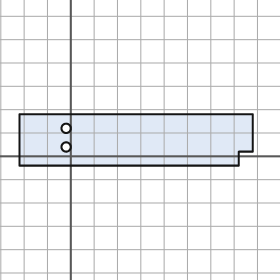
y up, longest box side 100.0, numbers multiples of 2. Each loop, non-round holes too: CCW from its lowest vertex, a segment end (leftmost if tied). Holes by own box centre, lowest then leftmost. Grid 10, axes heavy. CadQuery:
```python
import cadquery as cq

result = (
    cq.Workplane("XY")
    .moveTo(-22.0, -4.0)
    .lineTo(72.0, -4.0)
    .lineTo(72.0, 2.0)
    .lineTo(78.0, 2.0)
    .lineTo(78.0, 18.0)
    .lineTo(-22.0, 18.0)
    .close()
    .moveTo(-2.0, 4.0)
    .circle(2.0)
    .moveTo(-2.0, 12.0)
    .circle(2.0)
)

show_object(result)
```